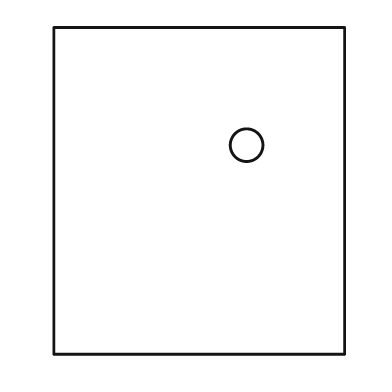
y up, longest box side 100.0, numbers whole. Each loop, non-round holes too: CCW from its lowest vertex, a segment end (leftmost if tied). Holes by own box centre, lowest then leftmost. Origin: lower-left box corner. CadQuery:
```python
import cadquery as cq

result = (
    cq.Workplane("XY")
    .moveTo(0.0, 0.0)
    .lineTo(89.0, 0.0)
    .lineTo(89.0, 100.0)
    .lineTo(0.0, 100.0)
    .close()
    .moveTo(59.0, 64.0)
    .circle(5.0)
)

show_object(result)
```